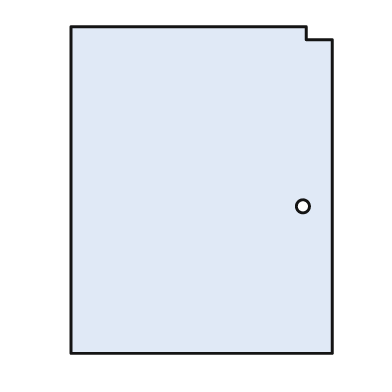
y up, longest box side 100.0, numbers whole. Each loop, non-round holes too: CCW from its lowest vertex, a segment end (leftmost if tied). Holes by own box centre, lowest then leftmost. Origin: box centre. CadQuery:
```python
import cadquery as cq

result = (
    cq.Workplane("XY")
    .moveTo(-40.0, -50.0)
    .lineTo(40.0, -50.0)
    .lineTo(40.0, 46.0)
    .lineTo(32.0, 46.0)
    .lineTo(32.0, 50.0)
    .lineTo(-40.0, 50.0)
    .close()
    .moveTo(31.0, -5.0)
    .circle(2.0)
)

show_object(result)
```